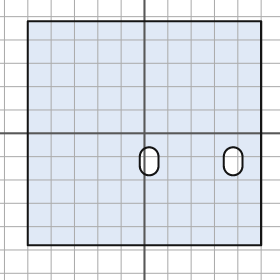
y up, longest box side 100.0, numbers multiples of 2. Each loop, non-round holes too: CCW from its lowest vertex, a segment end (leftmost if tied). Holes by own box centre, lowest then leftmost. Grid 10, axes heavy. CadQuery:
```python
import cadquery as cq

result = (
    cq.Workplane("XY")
    .moveTo(-50.0, -48.0)
    .lineTo(50.0, -48.0)
    .lineTo(50.0, 48.0)
    .lineTo(-50.0, 48.0)
    .close()
    .moveTo(-2.0, -14.0)
    .threePointArc((2.0, -18.0), (6.0, -14.0))
    .lineTo(6.0, -10.0)
    .threePointArc((2.0, -6.0), (-2.0, -10.0))
    .close()
    .moveTo(34.0, -14.0)
    .threePointArc((38.0, -18.0), (42.0, -14.0))
    .lineTo(42.0, -10.0)
    .threePointArc((38.0, -6.0), (34.0, -10.0))
    .close()
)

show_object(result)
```